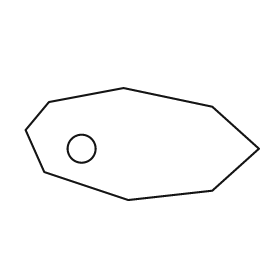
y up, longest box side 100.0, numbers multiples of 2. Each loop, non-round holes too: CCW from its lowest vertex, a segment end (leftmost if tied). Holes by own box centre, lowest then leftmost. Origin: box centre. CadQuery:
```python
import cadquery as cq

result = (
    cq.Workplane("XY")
    .moveTo(-6.0, -24.0)
    .lineTo(30.0, -20.0)
    .lineTo(50.0, -2.0)
    .lineTo(30.0, 16.0)
    .lineTo(-8.0, 24.0)
    .lineTo(-40.0, 18.0)
    .lineTo(-50.0, 6.0)
    .lineTo(-42.0, -12.0)
    .close()
    .moveTo(-26.0, -2.0)
    .circle(6.0)
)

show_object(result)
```